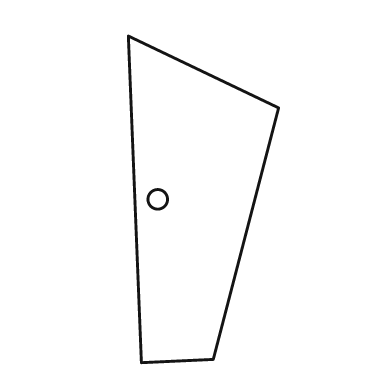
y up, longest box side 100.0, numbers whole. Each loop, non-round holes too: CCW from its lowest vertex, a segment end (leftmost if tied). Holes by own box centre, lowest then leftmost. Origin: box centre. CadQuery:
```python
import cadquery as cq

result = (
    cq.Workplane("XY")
    .moveTo(-19.0, -50.0)
    .lineTo(3.0, -49.0)
    .lineTo(23.0, 28.0)
    .lineTo(-23.0, 50.0)
    .close()
    .moveTo(-14.0, 0.0)
    .circle(3.0)
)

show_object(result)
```